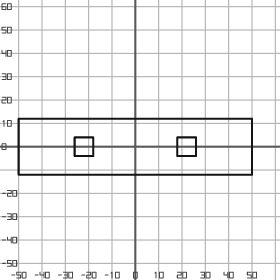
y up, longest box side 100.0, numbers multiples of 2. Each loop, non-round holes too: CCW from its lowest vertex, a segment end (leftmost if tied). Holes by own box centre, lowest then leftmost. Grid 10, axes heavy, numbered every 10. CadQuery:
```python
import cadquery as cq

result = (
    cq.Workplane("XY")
    .moveTo(-50.0, -12.0)
    .lineTo(50.0, -12.0)
    .lineTo(50.0, 12.0)
    .lineTo(-50.0, 12.0)
    .close()
    .moveTo(-26.0, -4.0)
    .lineTo(-18.0, -4.0)
    .lineTo(-18.0, 4.0)
    .lineTo(-26.0, 4.0)
    .close()
    .moveTo(18.0, -4.0)
    .lineTo(26.0, -4.0)
    .lineTo(26.0, 4.0)
    .lineTo(18.0, 4.0)
    .close()
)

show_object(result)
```